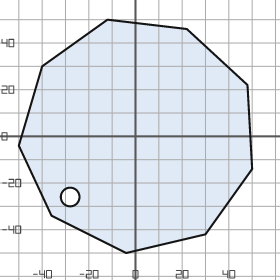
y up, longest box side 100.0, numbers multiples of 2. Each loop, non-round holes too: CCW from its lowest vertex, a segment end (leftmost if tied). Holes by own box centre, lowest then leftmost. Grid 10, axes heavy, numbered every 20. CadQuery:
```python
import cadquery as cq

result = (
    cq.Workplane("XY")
    .moveTo(-4.0, -50.0)
    .lineTo(30.0, -42.0)
    .lineTo(50.0, -14.0)
    .lineTo(48.0, 22.0)
    .lineTo(22.0, 46.0)
    .lineTo(-12.0, 50.0)
    .lineTo(-40.0, 30.0)
    .lineTo(-50.0, -4.0)
    .lineTo(-36.0, -34.0)
    .close()
    .moveTo(-28.0, -26.0)
    .circle(4.0)
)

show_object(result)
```